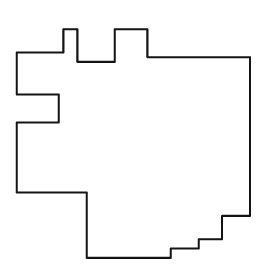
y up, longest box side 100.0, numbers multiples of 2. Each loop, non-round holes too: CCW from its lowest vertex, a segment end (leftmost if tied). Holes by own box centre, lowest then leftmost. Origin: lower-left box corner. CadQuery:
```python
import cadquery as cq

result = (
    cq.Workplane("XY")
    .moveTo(30.0, 0.0)
    .lineTo(66.0, 0.0)
    .lineTo(66.0, 4.0)
    .lineTo(78.0, 4.0)
    .lineTo(78.0, 8.0)
    .lineTo(88.0, 8.0)
    .lineTo(88.0, 18.0)
    .lineTo(100.0, 18.0)
    .lineTo(100.0, 86.0)
    .lineTo(56.0, 86.0)
    .lineTo(56.0, 98.0)
    .lineTo(42.0, 98.0)
    .lineTo(42.0, 84.0)
    .lineTo(26.0, 84.0)
    .lineTo(26.0, 98.0)
    .lineTo(20.0, 98.0)
    .lineTo(20.0, 88.0)
    .lineTo(0.0, 88.0)
    .lineTo(0.0, 70.0)
    .lineTo(18.0, 70.0)
    .lineTo(18.0, 58.0)
    .lineTo(0.0, 58.0)
    .lineTo(0.0, 28.0)
    .lineTo(30.0, 28.0)
    .close()
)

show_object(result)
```